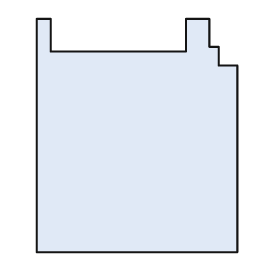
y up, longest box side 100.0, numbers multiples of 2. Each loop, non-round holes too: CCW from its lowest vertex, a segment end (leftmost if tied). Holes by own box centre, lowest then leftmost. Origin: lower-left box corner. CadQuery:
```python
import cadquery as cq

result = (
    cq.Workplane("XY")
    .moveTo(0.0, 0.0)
    .lineTo(86.0, 0.0)
    .lineTo(86.0, 80.0)
    .lineTo(78.0, 80.0)
    .lineTo(78.0, 88.0)
    .lineTo(74.0, 88.0)
    .lineTo(74.0, 100.0)
    .lineTo(64.0, 100.0)
    .lineTo(64.0, 86.0)
    .lineTo(6.0, 86.0)
    .lineTo(6.0, 100.0)
    .lineTo(0.0, 100.0)
    .close()
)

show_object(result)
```